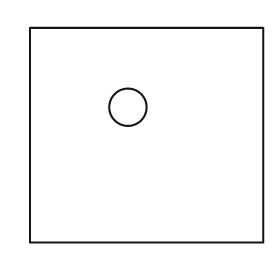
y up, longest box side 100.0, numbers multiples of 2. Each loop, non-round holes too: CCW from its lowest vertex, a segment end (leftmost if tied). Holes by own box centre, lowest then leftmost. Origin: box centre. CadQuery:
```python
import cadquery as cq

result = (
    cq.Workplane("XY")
    .moveTo(-50.0, -46.0)
    .lineTo(50.0, -46.0)
    .lineTo(50.0, 46.0)
    .lineTo(-50.0, 46.0)
    .close()
    .moveTo(-8.0, 12.0)
    .circle(8.0)
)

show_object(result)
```